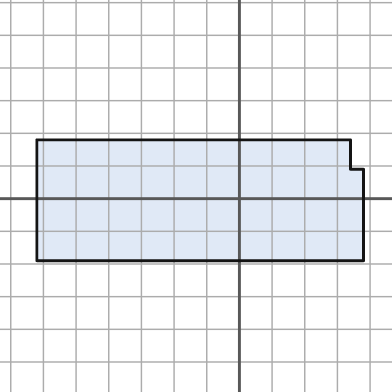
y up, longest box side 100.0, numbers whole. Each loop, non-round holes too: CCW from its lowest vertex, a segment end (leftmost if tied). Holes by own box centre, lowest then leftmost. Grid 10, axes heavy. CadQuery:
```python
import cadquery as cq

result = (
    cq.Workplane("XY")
    .moveTo(-62.0, -19.0)
    .lineTo(38.0, -19.0)
    .lineTo(38.0, 9.0)
    .lineTo(34.0, 9.0)
    .lineTo(34.0, 18.0)
    .lineTo(-62.0, 18.0)
    .close()
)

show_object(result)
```